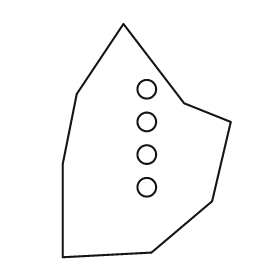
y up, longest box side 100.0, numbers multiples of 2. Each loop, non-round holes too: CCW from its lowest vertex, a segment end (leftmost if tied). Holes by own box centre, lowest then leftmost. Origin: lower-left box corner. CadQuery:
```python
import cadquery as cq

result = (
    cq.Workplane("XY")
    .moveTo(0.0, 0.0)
    .lineTo(38.0, 2.0)
    .lineTo(64.0, 24.0)
    .lineTo(72.0, 58.0)
    .lineTo(52.0, 66.0)
    .lineTo(26.0, 100.0)
    .lineTo(6.0, 70.0)
    .lineTo(0.0, 40.0)
    .close()
    .moveTo(36.0, 30.0)
    .circle(4.0)
    .moveTo(36.0, 44.0)
    .circle(4.0)
    .moveTo(36.0, 58.0)
    .circle(4.0)
    .moveTo(36.0, 72.0)
    .circle(4.0)
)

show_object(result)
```